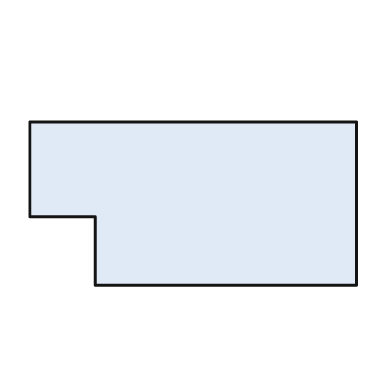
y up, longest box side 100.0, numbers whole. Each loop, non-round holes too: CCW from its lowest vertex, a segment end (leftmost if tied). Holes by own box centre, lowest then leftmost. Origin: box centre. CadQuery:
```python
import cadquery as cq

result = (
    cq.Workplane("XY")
    .moveTo(-30.0, -25.0)
    .lineTo(50.0, -25.0)
    .lineTo(50.0, 25.0)
    .lineTo(-50.0, 25.0)
    .lineTo(-50.0, -4.0)
    .lineTo(-30.0, -4.0)
    .close()
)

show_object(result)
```